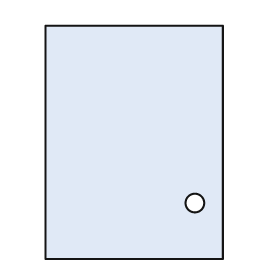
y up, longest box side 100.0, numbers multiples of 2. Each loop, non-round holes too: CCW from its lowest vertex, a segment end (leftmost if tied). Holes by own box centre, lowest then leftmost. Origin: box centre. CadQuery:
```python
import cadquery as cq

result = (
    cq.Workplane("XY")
    .moveTo(-38.0, -50.0)
    .lineTo(38.0, -50.0)
    .lineTo(38.0, 50.0)
    .lineTo(-38.0, 50.0)
    .close()
    .moveTo(26.0, -26.0)
    .circle(4.0)
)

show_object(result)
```